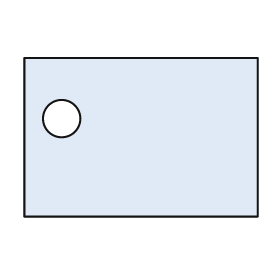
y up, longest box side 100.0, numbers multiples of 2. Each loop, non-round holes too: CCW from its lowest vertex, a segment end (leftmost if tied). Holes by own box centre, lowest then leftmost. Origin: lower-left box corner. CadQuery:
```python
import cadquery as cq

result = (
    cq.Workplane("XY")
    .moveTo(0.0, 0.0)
    .lineTo(100.0, 0.0)
    .lineTo(100.0, 68.0)
    .lineTo(0.0, 68.0)
    .close()
    .moveTo(16.0, 42.0)
    .circle(8.0)
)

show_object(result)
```